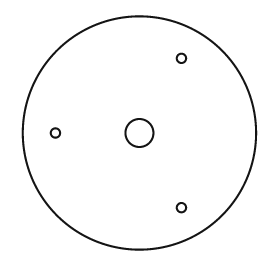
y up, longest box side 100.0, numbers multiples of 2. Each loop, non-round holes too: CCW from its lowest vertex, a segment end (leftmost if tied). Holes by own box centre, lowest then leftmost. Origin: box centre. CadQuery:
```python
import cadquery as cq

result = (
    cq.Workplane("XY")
    .moveTo(0.0, 0.0)
    .circle(50.0)
    .moveTo(18.0, -32.0)
    .circle(2.0)
    .moveTo(-36.0, 0.0)
    .circle(2.0)
    .moveTo(0.0, 0.0)
    .circle(6.0)
    .moveTo(18.0, 32.0)
    .circle(2.0)
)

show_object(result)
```